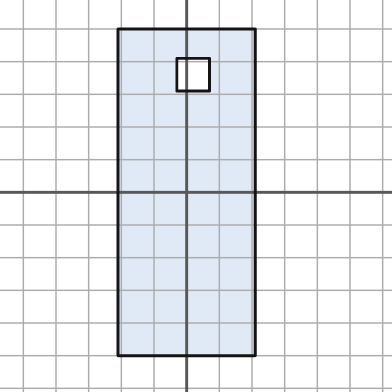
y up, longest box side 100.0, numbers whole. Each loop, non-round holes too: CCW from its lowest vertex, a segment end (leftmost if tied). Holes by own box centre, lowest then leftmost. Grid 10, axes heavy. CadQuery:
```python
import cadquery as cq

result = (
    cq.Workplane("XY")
    .moveTo(-21.0, -50.0)
    .lineTo(21.0, -50.0)
    .lineTo(21.0, 50.0)
    .lineTo(-21.0, 50.0)
    .close()
    .moveTo(-3.0, 31.0)
    .lineTo(7.0, 31.0)
    .lineTo(7.0, 41.0)
    .lineTo(-3.0, 41.0)
    .close()
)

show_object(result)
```